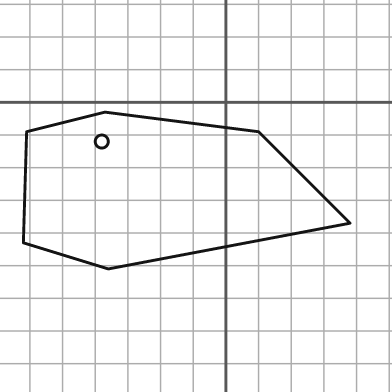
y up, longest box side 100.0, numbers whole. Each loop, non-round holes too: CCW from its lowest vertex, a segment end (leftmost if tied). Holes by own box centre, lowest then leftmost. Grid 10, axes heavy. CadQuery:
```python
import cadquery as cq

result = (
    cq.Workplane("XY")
    .moveTo(-36.0, -51.0)
    .lineTo(38.0, -37.0)
    .lineTo(10.0, -9.0)
    .lineTo(-37.0, -3.0)
    .lineTo(-61.0, -9.0)
    .lineTo(-62.0, -43.0)
    .close()
    .moveTo(-38.0, -12.0)
    .circle(2.0)
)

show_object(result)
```